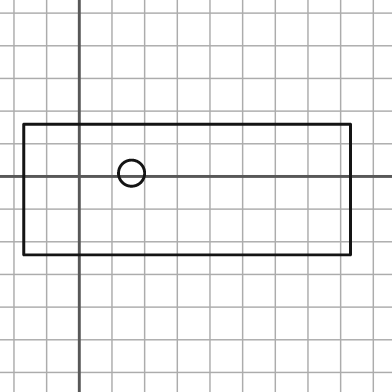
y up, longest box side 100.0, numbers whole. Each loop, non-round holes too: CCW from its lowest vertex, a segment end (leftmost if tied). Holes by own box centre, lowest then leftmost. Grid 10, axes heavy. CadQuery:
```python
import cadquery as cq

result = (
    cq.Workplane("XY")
    .moveTo(-17.0, -24.0)
    .lineTo(83.0, -24.0)
    .lineTo(83.0, 16.0)
    .lineTo(-17.0, 16.0)
    .close()
    .moveTo(16.0, 1.0)
    .circle(4.0)
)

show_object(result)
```